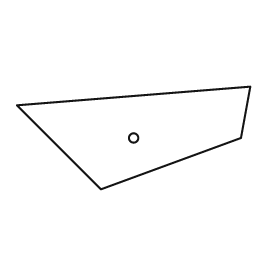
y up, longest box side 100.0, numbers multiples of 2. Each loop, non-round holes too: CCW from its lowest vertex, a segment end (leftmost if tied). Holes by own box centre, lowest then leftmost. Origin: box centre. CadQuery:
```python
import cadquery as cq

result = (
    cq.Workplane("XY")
    .moveTo(-14.0, -22.0)
    .lineTo(46.0, 0.0)
    .lineTo(50.0, 22.0)
    .lineTo(-50.0, 14.0)
    .close()
    .moveTo(0.0, 0.0)
    .circle(2.0)
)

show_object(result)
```